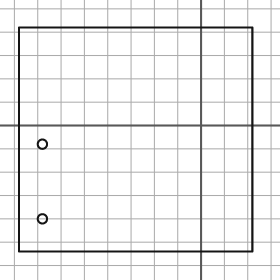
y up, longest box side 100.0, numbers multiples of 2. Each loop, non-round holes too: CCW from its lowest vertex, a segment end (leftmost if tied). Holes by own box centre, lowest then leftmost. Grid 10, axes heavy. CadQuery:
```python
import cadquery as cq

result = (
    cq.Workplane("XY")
    .moveTo(-78.0, -54.0)
    .lineTo(22.0, -54.0)
    .lineTo(22.0, 42.0)
    .lineTo(-78.0, 42.0)
    .close()
    .moveTo(-68.0, -40.0)
    .circle(2.0)
    .moveTo(-68.0, -8.0)
    .circle(2.0)
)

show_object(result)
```